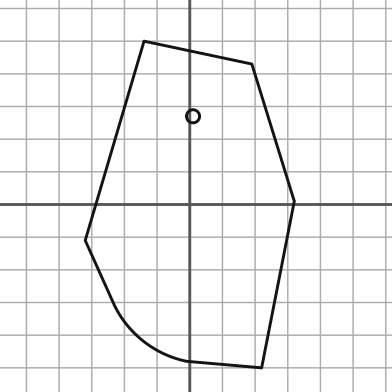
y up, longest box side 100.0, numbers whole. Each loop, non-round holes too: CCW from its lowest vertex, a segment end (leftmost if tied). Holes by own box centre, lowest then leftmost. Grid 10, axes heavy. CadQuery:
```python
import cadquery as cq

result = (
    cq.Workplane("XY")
    .moveTo(22.0, -50.0)
    .lineTo(32.0, 1.0)
    .lineTo(19.0, 43.0)
    .lineTo(-14.0, 50.0)
    .lineTo(-32.0, -11.0)
    .lineTo(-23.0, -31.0)
    .threePointArc((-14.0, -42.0), (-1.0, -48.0))
    .close()
    .moveTo(1.0, 27.0)
    .circle(2.0)
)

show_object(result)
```